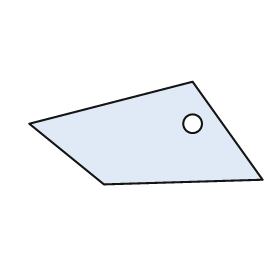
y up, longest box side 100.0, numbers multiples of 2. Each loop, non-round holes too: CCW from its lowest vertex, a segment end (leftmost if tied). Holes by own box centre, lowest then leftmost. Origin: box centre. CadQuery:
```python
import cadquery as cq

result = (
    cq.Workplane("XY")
    .moveTo(-18.0, -22.0)
    .lineTo(50.0, -20.0)
    .lineTo(20.0, 22.0)
    .lineTo(-50.0, 4.0)
    .close()
    .moveTo(20.0, 4.0)
    .circle(4.0)
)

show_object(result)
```